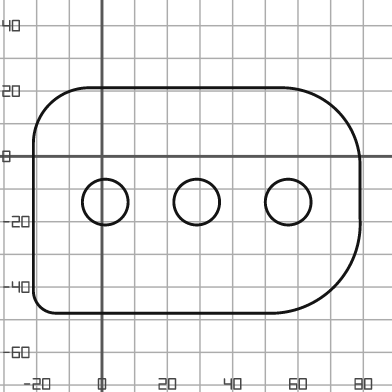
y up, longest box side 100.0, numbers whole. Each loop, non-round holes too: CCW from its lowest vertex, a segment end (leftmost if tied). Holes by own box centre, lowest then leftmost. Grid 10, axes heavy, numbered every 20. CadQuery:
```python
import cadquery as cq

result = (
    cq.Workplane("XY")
    .moveTo(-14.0, -48.0)
    .lineTo(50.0, -48.0)
    .threePointArc((71.0, -40.0), (79.0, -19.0))
    .lineTo(79.0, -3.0)
    .threePointArc((72.0, 14.0), (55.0, 21.0))
    .lineTo(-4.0, 21.0)
    .threePointArc((-16.0, 16.0), (-21.0, 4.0))
    .lineTo(-21.0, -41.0)
    .threePointArc((-19.0, -46.0), (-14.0, -48.0))
    .close()
    .moveTo(1.0, -14.0)
    .circle(7.0)
    .moveTo(29.0, -14.0)
    .circle(7.0)
    .moveTo(57.0, -14.0)
    .circle(7.0)
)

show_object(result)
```